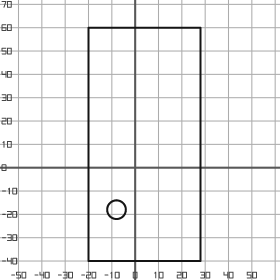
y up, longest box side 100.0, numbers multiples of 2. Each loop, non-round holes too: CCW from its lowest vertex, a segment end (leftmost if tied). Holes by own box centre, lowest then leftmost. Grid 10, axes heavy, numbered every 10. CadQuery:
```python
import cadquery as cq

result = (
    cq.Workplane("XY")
    .moveTo(-20.0, -40.0)
    .lineTo(28.0, -40.0)
    .lineTo(28.0, 60.0)
    .lineTo(-20.0, 60.0)
    .close()
    .moveTo(-8.0, -18.0)
    .circle(4.0)
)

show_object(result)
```